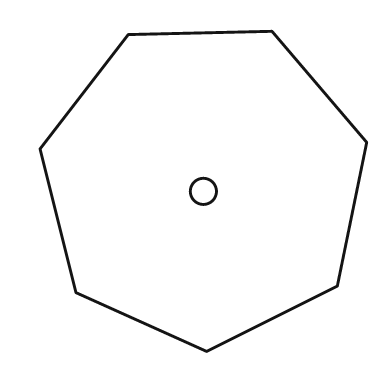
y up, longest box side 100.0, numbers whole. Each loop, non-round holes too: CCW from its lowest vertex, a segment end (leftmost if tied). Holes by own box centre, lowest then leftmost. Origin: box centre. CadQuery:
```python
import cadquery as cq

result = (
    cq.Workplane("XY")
    .moveTo(1.0, -49.0)
    .lineTo(41.0, -29.0)
    .lineTo(50.0, 15.0)
    .lineTo(21.0, 49.0)
    .lineTo(-23.0, 48.0)
    .lineTo(-50.0, 13.0)
    .lineTo(-39.0, -31.0)
    .close()
    .moveTo(0.0, 0.0)
    .circle(4.0)
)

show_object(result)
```